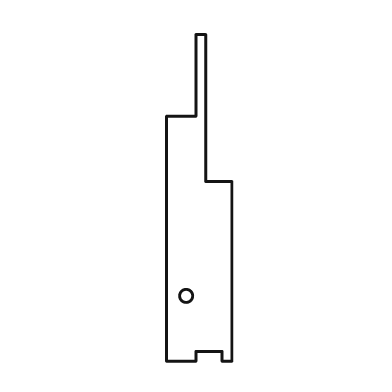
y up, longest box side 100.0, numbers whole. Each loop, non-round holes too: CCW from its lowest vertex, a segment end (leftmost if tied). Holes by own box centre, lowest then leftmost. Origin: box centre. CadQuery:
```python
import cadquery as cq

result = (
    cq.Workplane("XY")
    .moveTo(-10.0, -50.0)
    .lineTo(-1.0, -50.0)
    .lineTo(-1.0, -47.0)
    .lineTo(7.0, -47.0)
    .lineTo(7.0, -50.0)
    .lineTo(10.0, -50.0)
    .lineTo(10.0, 5.0)
    .lineTo(2.0, 5.0)
    .lineTo(2.0, 50.0)
    .lineTo(-1.0, 50.0)
    .lineTo(-1.0, 25.0)
    .lineTo(-10.0, 25.0)
    .close()
    .moveTo(-4.0, -30.0)
    .circle(2.0)
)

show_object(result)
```